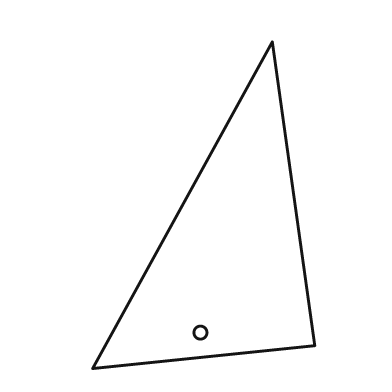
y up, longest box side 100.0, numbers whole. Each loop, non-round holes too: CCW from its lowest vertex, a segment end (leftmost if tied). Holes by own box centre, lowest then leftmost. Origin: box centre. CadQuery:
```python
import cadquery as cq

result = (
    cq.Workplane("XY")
    .moveTo(-34.0, -50.0)
    .lineTo(34.0, -43.0)
    .lineTo(21.0, 50.0)
    .close()
    .moveTo(-1.0, -39.0)
    .circle(2.0)
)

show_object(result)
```